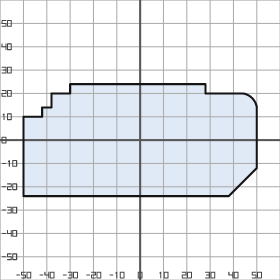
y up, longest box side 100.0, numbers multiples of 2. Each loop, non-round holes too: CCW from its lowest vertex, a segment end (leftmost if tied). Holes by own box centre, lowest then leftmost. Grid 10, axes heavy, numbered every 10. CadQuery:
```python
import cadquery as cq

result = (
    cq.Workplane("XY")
    .moveTo(-50.0, -24.0)
    .lineTo(38.0, -24.0)
    .lineTo(50.0, -12.0)
    .lineTo(50.0, 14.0)
    .threePointArc((48.0, 18.0), (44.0, 20.0))
    .lineTo(28.0, 20.0)
    .lineTo(28.0, 24.0)
    .lineTo(-30.0, 24.0)
    .lineTo(-30.0, 20.0)
    .lineTo(-38.0, 20.0)
    .lineTo(-38.0, 14.0)
    .lineTo(-42.0, 14.0)
    .lineTo(-42.0, 10.0)
    .lineTo(-50.0, 10.0)
    .close()
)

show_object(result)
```